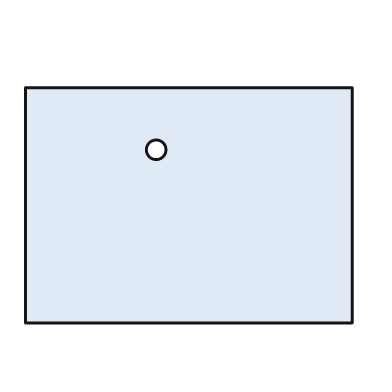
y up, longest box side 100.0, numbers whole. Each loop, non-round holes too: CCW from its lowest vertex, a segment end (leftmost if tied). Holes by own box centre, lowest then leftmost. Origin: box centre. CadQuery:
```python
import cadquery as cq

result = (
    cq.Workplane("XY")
    .moveTo(-50.0, -36.0)
    .lineTo(50.0, -36.0)
    .lineTo(50.0, 36.0)
    .lineTo(-50.0, 36.0)
    .close()
    .moveTo(-10.0, 17.0)
    .circle(3.0)
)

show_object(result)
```